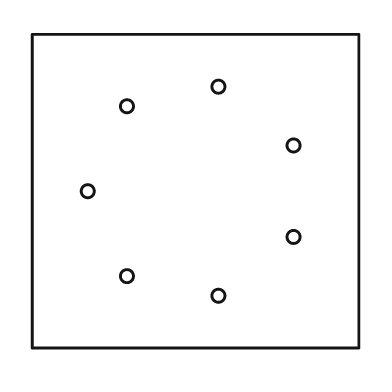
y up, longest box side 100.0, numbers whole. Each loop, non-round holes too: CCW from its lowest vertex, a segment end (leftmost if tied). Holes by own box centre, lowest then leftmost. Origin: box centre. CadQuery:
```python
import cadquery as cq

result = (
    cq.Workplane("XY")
    .moveTo(-50.0, -48.0)
    .lineTo(50.0, -48.0)
    .lineTo(50.0, 48.0)
    .lineTo(-50.0, 48.0)
    .close()
    .moveTo(7.0, -32.0)
    .circle(2.0)
    .moveTo(-21.0, -26.0)
    .circle(2.0)
    .moveTo(30.0, -14.0)
    .circle(2.0)
    .moveTo(-33.0, 0.0)
    .circle(2.0)
    .moveTo(30.0, 14.0)
    .circle(2.0)
    .moveTo(-21.0, 26.0)
    .circle(2.0)
    .moveTo(7.0, 32.0)
    .circle(2.0)
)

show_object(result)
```